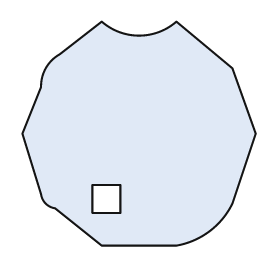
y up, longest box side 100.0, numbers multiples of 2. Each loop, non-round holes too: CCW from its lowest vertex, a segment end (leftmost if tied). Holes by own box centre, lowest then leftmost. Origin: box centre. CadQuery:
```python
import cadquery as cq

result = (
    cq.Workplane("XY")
    .moveTo(-16.0, -48.0)
    .lineTo(16.0, -48.0)
    .threePointArc((30.0, -42.0), (40.0, -30.0))
    .lineTo(50.0, 0.0)
    .lineTo(40.0, 28.0)
    .lineTo(16.0, 48.0)
    .threePointArc((0.0, 42.0), (-16.0, 48.0))
    .lineTo(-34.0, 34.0)
    .threePointArc((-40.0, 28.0), (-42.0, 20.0))
    .lineTo(-50.0, 0.0)
    .lineTo(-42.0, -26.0)
    .threePointArc((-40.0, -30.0), (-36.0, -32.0))
    .close()
    .moveTo(-20.0, -34.0)
    .lineTo(-8.0, -34.0)
    .lineTo(-8.0, -22.0)
    .lineTo(-20.0, -22.0)
    .close()
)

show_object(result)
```